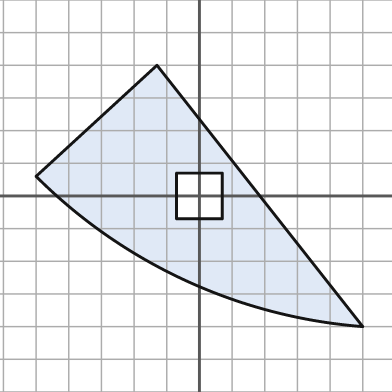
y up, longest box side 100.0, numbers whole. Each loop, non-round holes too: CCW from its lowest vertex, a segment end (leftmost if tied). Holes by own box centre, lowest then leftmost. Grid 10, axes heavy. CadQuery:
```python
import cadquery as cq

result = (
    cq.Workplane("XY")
    .moveTo(50.0, -40.0)
    .lineTo(-13.0, 40.0)
    .lineTo(-50.0, 6.0)
    .threePointArc((-4.0, -26.0), (50.0, -40.0))
    .close()
    .moveTo(-7.0, -7.0)
    .lineTo(7.0, -7.0)
    .lineTo(7.0, 7.0)
    .lineTo(-7.0, 7.0)
    .close()
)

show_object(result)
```